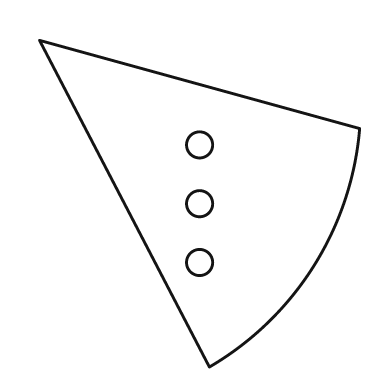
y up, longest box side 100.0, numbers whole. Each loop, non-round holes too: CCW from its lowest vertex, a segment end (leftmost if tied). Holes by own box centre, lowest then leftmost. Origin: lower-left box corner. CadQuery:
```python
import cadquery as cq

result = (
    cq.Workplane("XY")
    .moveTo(52.0, 0.0)
    .threePointArc((84.0, 31.0), (98.0, 73.0))
    .lineTo(0.0, 100.0)
    .close()
    .moveTo(49.0, 32.0)
    .circle(4.0)
    .moveTo(49.0, 50.0)
    .circle(4.0)
    .moveTo(49.0, 68.0)
    .circle(4.0)
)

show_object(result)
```